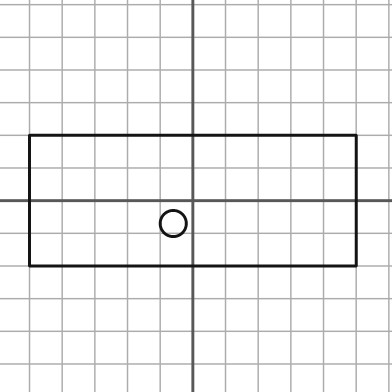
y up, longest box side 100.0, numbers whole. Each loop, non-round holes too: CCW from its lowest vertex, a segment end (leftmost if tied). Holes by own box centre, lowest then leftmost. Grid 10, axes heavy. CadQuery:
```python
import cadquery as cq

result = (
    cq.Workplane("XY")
    .moveTo(-50.0, -20.0)
    .lineTo(50.0, -20.0)
    .lineTo(50.0, 20.0)
    .lineTo(-50.0, 20.0)
    .close()
    .moveTo(-6.0, -7.0)
    .circle(4.0)
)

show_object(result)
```